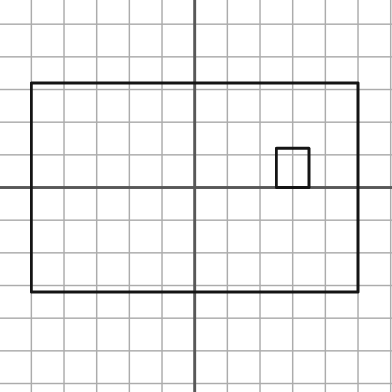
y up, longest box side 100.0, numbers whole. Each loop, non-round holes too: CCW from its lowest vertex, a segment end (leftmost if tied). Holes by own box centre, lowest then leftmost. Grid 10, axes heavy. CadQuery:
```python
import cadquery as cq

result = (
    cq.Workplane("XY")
    .moveTo(-50.0, -32.0)
    .lineTo(50.0, -32.0)
    .lineTo(50.0, 32.0)
    .lineTo(-50.0, 32.0)
    .close()
    .moveTo(25.0, 0.0)
    .lineTo(35.0, 0.0)
    .lineTo(35.0, 12.0)
    .lineTo(25.0, 12.0)
    .close()
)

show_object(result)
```